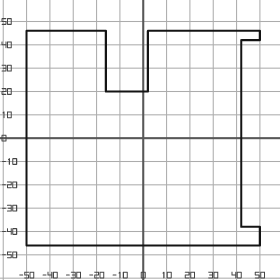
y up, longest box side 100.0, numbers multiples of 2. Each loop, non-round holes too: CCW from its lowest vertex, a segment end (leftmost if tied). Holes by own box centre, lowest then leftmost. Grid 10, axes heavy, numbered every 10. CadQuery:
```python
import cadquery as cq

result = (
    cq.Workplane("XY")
    .moveTo(-50.0, -46.0)
    .lineTo(50.0, -46.0)
    .lineTo(50.0, -38.0)
    .lineTo(42.0, -38.0)
    .lineTo(42.0, 42.0)
    .lineTo(50.0, 42.0)
    .lineTo(50.0, 46.0)
    .lineTo(2.0, 46.0)
    .lineTo(2.0, 20.0)
    .lineTo(-16.0, 20.0)
    .lineTo(-16.0, 46.0)
    .lineTo(-50.0, 46.0)
    .close()
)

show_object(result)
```